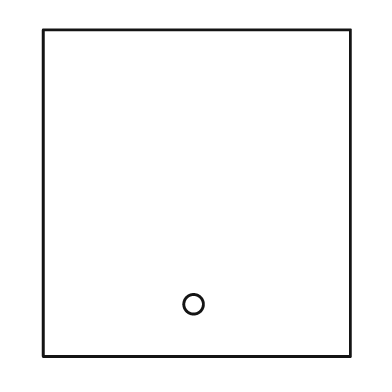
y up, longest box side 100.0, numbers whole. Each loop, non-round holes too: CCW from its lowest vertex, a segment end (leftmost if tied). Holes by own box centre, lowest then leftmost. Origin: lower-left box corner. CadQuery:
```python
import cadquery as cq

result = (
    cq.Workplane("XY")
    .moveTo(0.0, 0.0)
    .lineTo(94.0, 0.0)
    .lineTo(94.0, 100.0)
    .lineTo(0.0, 100.0)
    .close()
    .moveTo(46.0, 16.0)
    .circle(3.0)
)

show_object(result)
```